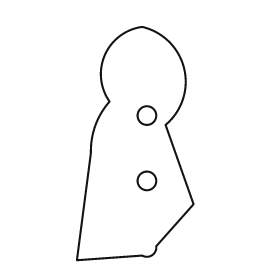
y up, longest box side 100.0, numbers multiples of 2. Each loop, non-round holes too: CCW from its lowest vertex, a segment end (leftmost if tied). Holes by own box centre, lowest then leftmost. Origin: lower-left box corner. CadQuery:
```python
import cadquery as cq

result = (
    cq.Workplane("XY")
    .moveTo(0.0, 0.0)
    .lineTo(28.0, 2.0)
    .threePointArc((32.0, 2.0), (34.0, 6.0))
    .lineTo(50.0, 24.0)
    .lineTo(38.0, 58.0)
    .threePointArc((46.0, 82.0), (28.0, 100.0))
    .threePointArc((12.0, 88.0), (14.0, 68.0))
    .threePointArc((8.0, 58.0), (6.0, 46.0))
    .close()
    .moveTo(30.0, 34.0)
    .circle(4.0)
    .moveTo(30.0, 62.0)
    .circle(4.0)
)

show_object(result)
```